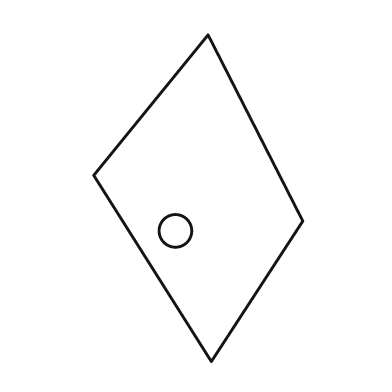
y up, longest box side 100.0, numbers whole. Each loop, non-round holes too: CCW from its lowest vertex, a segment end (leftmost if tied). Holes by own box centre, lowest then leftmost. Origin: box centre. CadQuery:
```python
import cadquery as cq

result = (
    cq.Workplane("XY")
    .moveTo(4.0, -50.0)
    .lineTo(32.0, -7.0)
    .lineTo(3.0, 50.0)
    .lineTo(-32.0, 7.0)
    .close()
    .moveTo(-7.0, -10.0)
    .circle(5.0)
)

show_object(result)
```